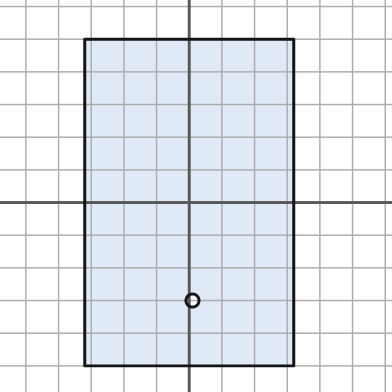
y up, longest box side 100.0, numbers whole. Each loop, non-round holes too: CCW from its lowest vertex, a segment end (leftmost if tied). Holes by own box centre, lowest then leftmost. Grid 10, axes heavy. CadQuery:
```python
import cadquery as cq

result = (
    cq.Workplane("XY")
    .moveTo(-32.0, -50.0)
    .lineTo(32.0, -50.0)
    .lineTo(32.0, 50.0)
    .lineTo(-32.0, 50.0)
    .close()
    .moveTo(1.0, -30.0)
    .circle(2.0)
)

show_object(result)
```